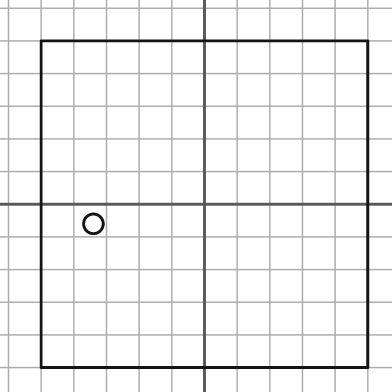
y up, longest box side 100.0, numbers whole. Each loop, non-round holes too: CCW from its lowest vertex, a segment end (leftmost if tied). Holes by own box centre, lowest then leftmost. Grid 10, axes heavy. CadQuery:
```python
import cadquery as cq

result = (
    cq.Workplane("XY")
    .moveTo(-50.0, -50.0)
    .lineTo(50.0, -50.0)
    .lineTo(50.0, 50.0)
    .lineTo(-50.0, 50.0)
    .close()
    .moveTo(-34.0, -6.0)
    .circle(3.0)
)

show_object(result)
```